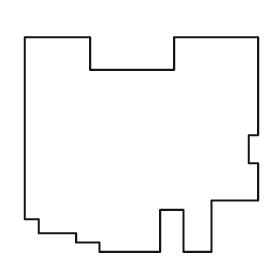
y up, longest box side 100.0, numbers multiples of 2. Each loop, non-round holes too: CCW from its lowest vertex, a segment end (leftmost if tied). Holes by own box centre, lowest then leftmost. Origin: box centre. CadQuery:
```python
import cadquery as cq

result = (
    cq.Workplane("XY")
    .moveTo(-18.0, -46.0)
    .lineTo(8.0, -46.0)
    .lineTo(8.0, -28.0)
    .lineTo(18.0, -28.0)
    .lineTo(18.0, -46.0)
    .lineTo(30.0, -46.0)
    .lineTo(30.0, -24.0)
    .lineTo(50.0, -24.0)
    .lineTo(50.0, -8.0)
    .lineTo(46.0, -8.0)
    .lineTo(46.0, 4.0)
    .lineTo(50.0, 4.0)
    .lineTo(50.0, 46.0)
    .lineTo(14.0, 46.0)
    .lineTo(14.0, 32.0)
    .lineTo(-22.0, 32.0)
    .lineTo(-22.0, 46.0)
    .lineTo(-50.0, 46.0)
    .lineTo(-50.0, -32.0)
    .lineTo(-44.0, -32.0)
    .lineTo(-44.0, -38.0)
    .lineTo(-28.0, -38.0)
    .lineTo(-28.0, -42.0)
    .lineTo(-18.0, -42.0)
    .close()
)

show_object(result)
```